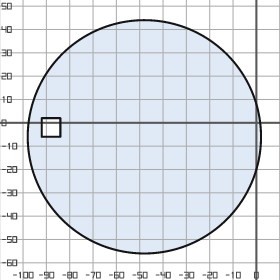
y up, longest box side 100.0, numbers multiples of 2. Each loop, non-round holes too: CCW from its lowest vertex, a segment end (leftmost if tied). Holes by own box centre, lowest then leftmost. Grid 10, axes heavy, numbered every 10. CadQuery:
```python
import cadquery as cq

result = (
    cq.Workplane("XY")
    .moveTo(-48.0, -6.0)
    .circle(50.0)
    .moveTo(-92.0, -6.0)
    .lineTo(-84.0, -6.0)
    .lineTo(-84.0, 2.0)
    .lineTo(-92.0, 2.0)
    .close()
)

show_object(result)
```